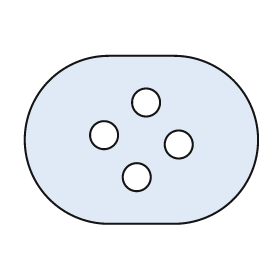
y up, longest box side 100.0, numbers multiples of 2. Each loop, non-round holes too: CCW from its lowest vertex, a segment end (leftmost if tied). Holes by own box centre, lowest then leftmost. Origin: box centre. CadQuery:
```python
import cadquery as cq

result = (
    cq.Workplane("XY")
    .moveTo(-14.0, -36.0)
    .lineTo(14.0, -36.0)
    .threePointArc((50.0, 0.0), (14.0, 36.0))
    .lineTo(-14.0, 36.0)
    .threePointArc((-50.0, 0.0), (-14.0, -36.0))
    .close()
    .moveTo(-2.0, -16.0)
    .circle(6.0)
    .moveTo(16.0, -2.0)
    .circle(6.0)
    .moveTo(-16.0, 2.0)
    .circle(6.0)
    .moveTo(2.0, 16.0)
    .circle(6.0)
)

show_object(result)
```